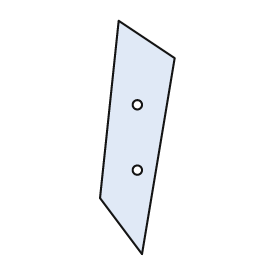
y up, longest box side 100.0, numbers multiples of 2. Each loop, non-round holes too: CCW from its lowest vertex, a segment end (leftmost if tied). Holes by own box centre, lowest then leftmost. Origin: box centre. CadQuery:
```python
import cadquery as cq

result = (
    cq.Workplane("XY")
    .moveTo(2.0, -50.0)
    .lineTo(16.0, 34.0)
    .lineTo(-8.0, 50.0)
    .lineTo(-16.0, -26.0)
    .close()
    .moveTo(0.0, -14.0)
    .circle(2.0)
    .moveTo(0.0, 14.0)
    .circle(2.0)
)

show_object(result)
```